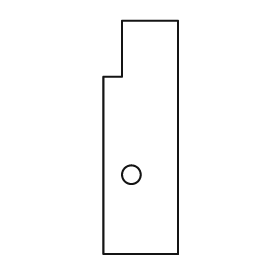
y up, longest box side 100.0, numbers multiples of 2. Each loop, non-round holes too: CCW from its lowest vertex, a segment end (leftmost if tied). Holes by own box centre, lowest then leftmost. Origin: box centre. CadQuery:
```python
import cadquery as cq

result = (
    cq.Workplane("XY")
    .moveTo(-16.0, -50.0)
    .lineTo(16.0, -50.0)
    .lineTo(16.0, 50.0)
    .lineTo(-8.0, 50.0)
    .lineTo(-8.0, 26.0)
    .lineTo(-16.0, 26.0)
    .close()
    .moveTo(-4.0, -16.0)
    .circle(4.0)
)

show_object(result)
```